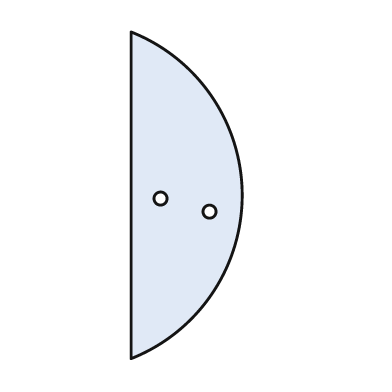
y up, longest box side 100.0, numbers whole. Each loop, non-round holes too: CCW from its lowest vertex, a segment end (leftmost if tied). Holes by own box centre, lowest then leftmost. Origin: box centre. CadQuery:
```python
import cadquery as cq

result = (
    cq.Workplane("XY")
    .moveTo(-17.0, -50.0)
    .threePointArc((17.0, 0.0), (-17.0, 50.0))
    .close()
    .moveTo(7.0, -5.0)
    .circle(2.0)
    .moveTo(-8.0, -1.0)
    .circle(2.0)
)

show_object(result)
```